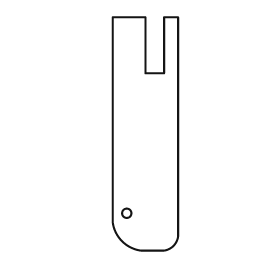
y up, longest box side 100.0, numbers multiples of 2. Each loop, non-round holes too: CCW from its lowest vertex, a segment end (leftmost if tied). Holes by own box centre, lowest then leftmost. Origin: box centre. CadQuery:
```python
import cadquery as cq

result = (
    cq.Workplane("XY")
    .moveTo(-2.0, -50.0)
    .lineTo(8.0, -50.0)
    .threePointArc((12.0, -48.0), (14.0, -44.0))
    .lineTo(14.0, 50.0)
    .lineTo(8.0, 50.0)
    .lineTo(8.0, 26.0)
    .lineTo(0.0, 26.0)
    .lineTo(0.0, 50.0)
    .lineTo(-14.0, 50.0)
    .lineTo(-14.0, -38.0)
    .threePointArc((-10.0, -46.0), (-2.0, -50.0))
    .close()
    .moveTo(-8.0, -34.0)
    .circle(2.0)
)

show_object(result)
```